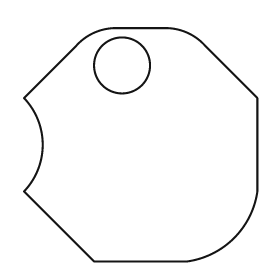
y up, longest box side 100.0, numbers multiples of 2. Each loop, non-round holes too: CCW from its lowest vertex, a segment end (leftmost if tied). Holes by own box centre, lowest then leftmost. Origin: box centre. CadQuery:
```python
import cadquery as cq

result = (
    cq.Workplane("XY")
    .moveTo(-20.0, -50.0)
    .lineTo(20.0, -50.0)
    .threePointArc((40.0, -40.0), (50.0, -20.0))
    .lineTo(50.0, 20.0)
    .lineTo(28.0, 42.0)
    .threePointArc((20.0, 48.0), (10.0, 50.0))
    .lineTo(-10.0, 50.0)
    .threePointArc((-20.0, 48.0), (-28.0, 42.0))
    .lineTo(-50.0, 20.0)
    .threePointArc((-42.0, 0.0), (-50.0, -20.0))
    .close()
    .moveTo(-8.0, 34.0)
    .circle(12.0)
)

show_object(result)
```